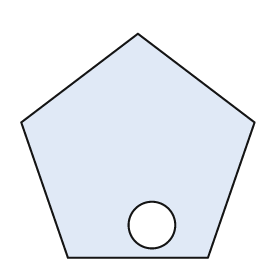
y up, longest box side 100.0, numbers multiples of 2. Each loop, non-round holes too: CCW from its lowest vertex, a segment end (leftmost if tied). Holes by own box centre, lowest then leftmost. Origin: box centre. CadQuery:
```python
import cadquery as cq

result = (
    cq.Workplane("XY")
    .moveTo(-30.0, -48.0)
    .lineTo(30.0, -48.0)
    .lineTo(50.0, 10.0)
    .lineTo(0.0, 48.0)
    .lineTo(-50.0, 10.0)
    .close()
    .moveTo(6.0, -34.0)
    .circle(10.0)
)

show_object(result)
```